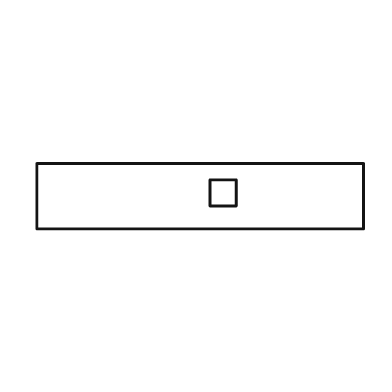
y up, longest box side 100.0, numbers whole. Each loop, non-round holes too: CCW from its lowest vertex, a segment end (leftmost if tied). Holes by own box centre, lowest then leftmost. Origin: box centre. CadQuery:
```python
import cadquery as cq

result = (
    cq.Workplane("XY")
    .moveTo(-50.0, -10.0)
    .lineTo(50.0, -10.0)
    .lineTo(50.0, 10.0)
    .lineTo(-50.0, 10.0)
    .close()
    .moveTo(3.0, -3.0)
    .lineTo(11.0, -3.0)
    .lineTo(11.0, 5.0)
    .lineTo(3.0, 5.0)
    .close()
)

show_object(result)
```